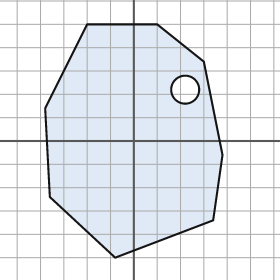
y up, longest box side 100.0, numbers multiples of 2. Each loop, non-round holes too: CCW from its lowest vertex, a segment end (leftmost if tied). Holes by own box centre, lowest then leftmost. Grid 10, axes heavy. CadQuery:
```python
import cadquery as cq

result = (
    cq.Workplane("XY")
    .moveTo(-8.0, -50.0)
    .lineTo(34.0, -34.0)
    .lineTo(38.0, -6.0)
    .lineTo(30.0, 34.0)
    .lineTo(10.0, 50.0)
    .lineTo(-20.0, 50.0)
    .lineTo(-38.0, 14.0)
    .lineTo(-36.0, -24.0)
    .close()
    .moveTo(22.0, 22.0)
    .circle(6.0)
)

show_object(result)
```